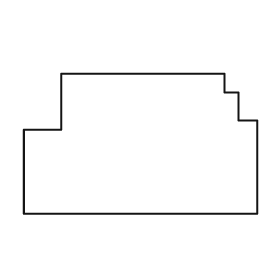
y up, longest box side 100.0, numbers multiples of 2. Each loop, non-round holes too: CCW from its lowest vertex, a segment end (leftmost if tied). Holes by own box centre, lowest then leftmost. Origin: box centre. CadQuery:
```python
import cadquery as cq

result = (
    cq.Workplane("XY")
    .moveTo(-50.0, -30.0)
    .lineTo(50.0, -30.0)
    .lineTo(50.0, 10.0)
    .lineTo(42.0, 10.0)
    .lineTo(42.0, 22.0)
    .lineTo(36.0, 22.0)
    .lineTo(36.0, 30.0)
    .lineTo(-34.0, 30.0)
    .lineTo(-34.0, 6.0)
    .lineTo(-50.0, 6.0)
    .close()
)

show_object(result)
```